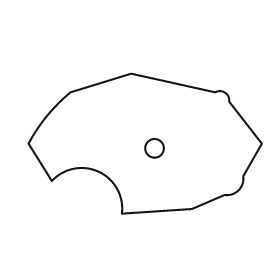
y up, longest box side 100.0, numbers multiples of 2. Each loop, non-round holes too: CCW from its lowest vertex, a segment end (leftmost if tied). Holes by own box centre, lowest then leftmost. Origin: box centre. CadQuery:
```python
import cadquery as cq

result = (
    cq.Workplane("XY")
    .moveTo(-10.0, -30.0)
    .lineTo(20.0, -28.0)
    .lineTo(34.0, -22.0)
    .threePointArc((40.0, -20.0), (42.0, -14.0))
    .lineTo(50.0, 0.0)
    .lineTo(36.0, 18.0)
    .threePointArc((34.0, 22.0), (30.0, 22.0))
    .lineTo(-6.0, 30.0)
    .lineTo(-32.0, 22.0)
    .threePointArc((-42.0, 12.0), (-50.0, 0.0))
    .lineTo(-40.0, -16.0)
    .threePointArc((-20.0, -12.0), (-10.0, -30.0))
    .close()
    .moveTo(4.0, -2.0)
    .circle(4.0)
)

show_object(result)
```